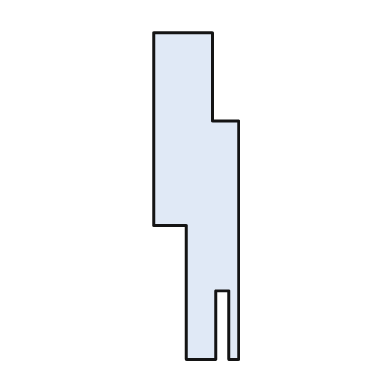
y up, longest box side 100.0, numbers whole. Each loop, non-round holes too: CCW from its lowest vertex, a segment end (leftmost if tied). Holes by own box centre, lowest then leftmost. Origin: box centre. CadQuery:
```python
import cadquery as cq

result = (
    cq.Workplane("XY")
    .moveTo(-3.0, -50.0)
    .lineTo(6.0, -50.0)
    .lineTo(6.0, -29.0)
    .lineTo(10.0, -29.0)
    .lineTo(10.0, -50.0)
    .lineTo(13.0, -50.0)
    .lineTo(13.0, 23.0)
    .lineTo(5.0, 23.0)
    .lineTo(5.0, 50.0)
    .lineTo(-13.0, 50.0)
    .lineTo(-13.0, -9.0)
    .lineTo(-3.0, -9.0)
    .close()
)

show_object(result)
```